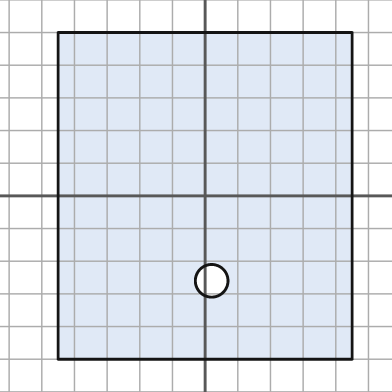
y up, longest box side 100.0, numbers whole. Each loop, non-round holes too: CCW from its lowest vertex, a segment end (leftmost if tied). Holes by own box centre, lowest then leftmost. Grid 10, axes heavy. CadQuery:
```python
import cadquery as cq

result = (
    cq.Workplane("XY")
    .moveTo(-45.0, -50.0)
    .lineTo(45.0, -50.0)
    .lineTo(45.0, 50.0)
    .lineTo(-45.0, 50.0)
    .close()
    .moveTo(2.0, -26.0)
    .circle(5.0)
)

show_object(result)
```